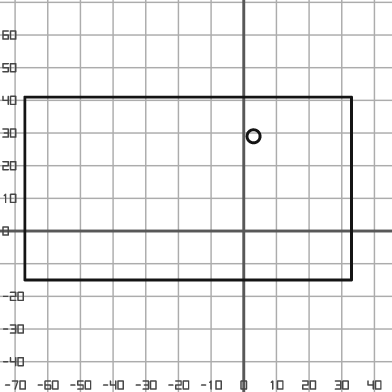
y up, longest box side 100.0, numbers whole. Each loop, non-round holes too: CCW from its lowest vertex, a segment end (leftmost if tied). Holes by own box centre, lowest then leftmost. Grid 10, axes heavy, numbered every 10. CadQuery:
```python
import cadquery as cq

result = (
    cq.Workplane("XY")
    .moveTo(-67.0, -15.0)
    .lineTo(33.0, -15.0)
    .lineTo(33.0, 41.0)
    .lineTo(-67.0, 41.0)
    .close()
    .moveTo(3.0, 29.0)
    .circle(2.0)
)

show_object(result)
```